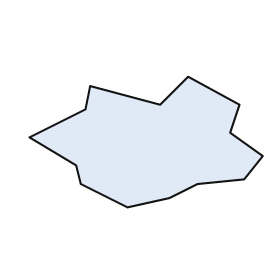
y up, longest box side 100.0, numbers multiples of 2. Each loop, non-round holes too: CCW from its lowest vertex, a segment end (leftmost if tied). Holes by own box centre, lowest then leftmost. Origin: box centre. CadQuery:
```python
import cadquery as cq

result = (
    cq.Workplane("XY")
    .moveTo(-8.0, -28.0)
    .lineTo(10.0, -24.0)
    .lineTo(22.0, -18.0)
    .lineTo(42.0, -16.0)
    .lineTo(50.0, -6.0)
    .lineTo(36.0, 4.0)
    .lineTo(40.0, 16.0)
    .lineTo(18.0, 28.0)
    .lineTo(6.0, 16.0)
    .lineTo(-24.0, 24.0)
    .lineTo(-26.0, 14.0)
    .lineTo(-50.0, 2.0)
    .lineTo(-30.0, -10.0)
    .lineTo(-28.0, -18.0)
    .close()
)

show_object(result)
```